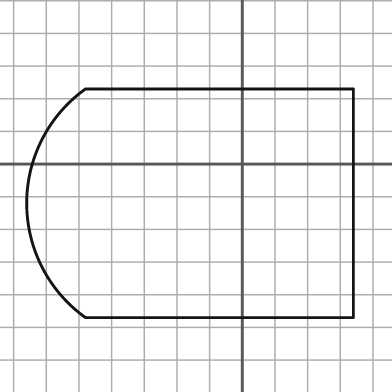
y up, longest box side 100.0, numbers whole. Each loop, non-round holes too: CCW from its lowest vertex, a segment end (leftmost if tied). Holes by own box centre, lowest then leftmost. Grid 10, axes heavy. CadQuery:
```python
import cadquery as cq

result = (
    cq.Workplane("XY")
    .moveTo(-48.0, -47.0)
    .lineTo(34.0, -47.0)
    .lineTo(34.0, 23.0)
    .lineTo(-48.0, 23.0)
    .threePointArc((-66.0, -12.0), (-48.0, -47.0))
    .close()
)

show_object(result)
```